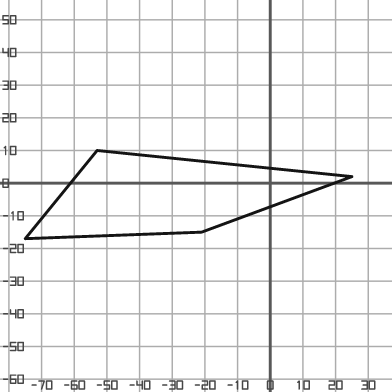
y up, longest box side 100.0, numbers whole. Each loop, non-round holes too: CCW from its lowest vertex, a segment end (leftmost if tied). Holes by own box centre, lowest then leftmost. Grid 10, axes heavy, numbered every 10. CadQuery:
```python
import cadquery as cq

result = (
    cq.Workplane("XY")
    .moveTo(-75.0, -17.0)
    .lineTo(-21.0, -15.0)
    .lineTo(25.0, 2.0)
    .lineTo(-53.0, 10.0)
    .close()
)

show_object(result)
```